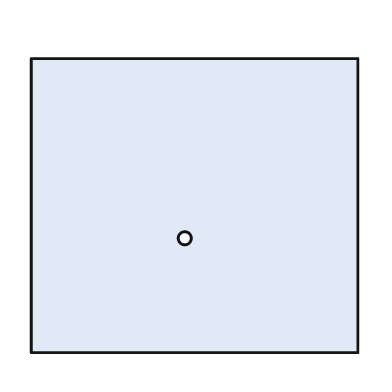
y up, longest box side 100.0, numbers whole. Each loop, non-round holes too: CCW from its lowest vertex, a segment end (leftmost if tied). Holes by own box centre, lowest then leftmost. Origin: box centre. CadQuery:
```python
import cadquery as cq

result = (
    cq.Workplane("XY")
    .moveTo(-50.0, -45.0)
    .lineTo(50.0, -45.0)
    .lineTo(50.0, 45.0)
    .lineTo(-50.0, 45.0)
    .close()
    .moveTo(-3.0, -10.0)
    .circle(2.0)
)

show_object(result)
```